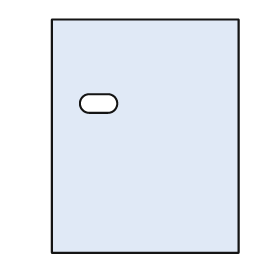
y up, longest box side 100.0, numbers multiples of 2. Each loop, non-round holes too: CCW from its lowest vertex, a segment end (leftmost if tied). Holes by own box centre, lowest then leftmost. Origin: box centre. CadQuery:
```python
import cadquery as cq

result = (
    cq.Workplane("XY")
    .moveTo(-40.0, -50.0)
    .lineTo(40.0, -50.0)
    .lineTo(40.0, 50.0)
    .lineTo(-40.0, 50.0)
    .close()
    .moveTo(-24.0, 10.0)
    .lineTo(-16.0, 10.0)
    .threePointArc((-12.0, 14.0), (-16.0, 18.0))
    .lineTo(-24.0, 18.0)
    .threePointArc((-28.0, 14.0), (-24.0, 10.0))
    .close()
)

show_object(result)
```